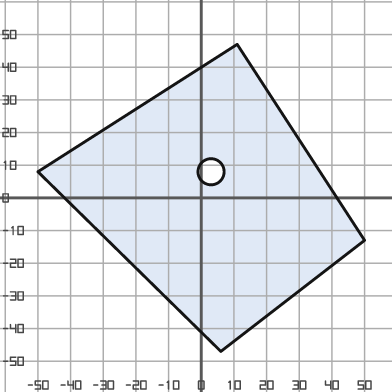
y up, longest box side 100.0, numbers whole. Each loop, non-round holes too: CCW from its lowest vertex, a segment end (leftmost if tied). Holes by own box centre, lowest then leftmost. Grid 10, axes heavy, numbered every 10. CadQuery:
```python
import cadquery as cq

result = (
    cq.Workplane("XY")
    .moveTo(6.0, -47.0)
    .lineTo(50.0, -13.0)
    .lineTo(11.0, 47.0)
    .lineTo(-50.0, 8.0)
    .close()
    .moveTo(3.0, 8.0)
    .circle(4.0)
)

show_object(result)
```